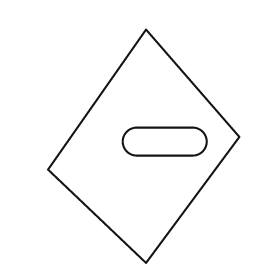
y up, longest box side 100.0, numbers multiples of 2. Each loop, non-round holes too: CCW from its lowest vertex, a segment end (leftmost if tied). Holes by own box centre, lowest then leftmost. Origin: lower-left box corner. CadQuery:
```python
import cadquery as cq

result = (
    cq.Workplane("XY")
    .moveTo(42.0, 0.0)
    .lineTo(82.0, 54.0)
    .lineTo(42.0, 100.0)
    .lineTo(0.0, 40.0)
    .close()
    .moveTo(38.0, 46.0)
    .lineTo(62.0, 46.0)
    .threePointArc((68.0, 52.0), (62.0, 58.0))
    .lineTo(38.0, 58.0)
    .threePointArc((32.0, 52.0), (38.0, 46.0))
    .close()
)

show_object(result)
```